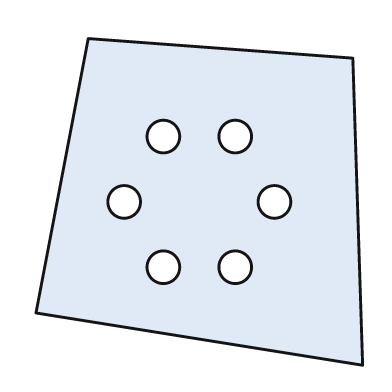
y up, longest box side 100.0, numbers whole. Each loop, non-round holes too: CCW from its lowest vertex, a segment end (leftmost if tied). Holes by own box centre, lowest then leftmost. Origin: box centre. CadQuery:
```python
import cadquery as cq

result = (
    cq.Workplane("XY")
    .moveTo(50.0, -50.0)
    .lineTo(47.0, 44.0)
    .lineTo(-34.0, 50.0)
    .lineTo(-50.0, -34.0)
    .close()
    .moveTo(-11.0, -20.0)
    .circle(5.0)
    .moveTo(11.0, -20.0)
    .circle(5.0)
    .moveTo(-23.0, 0.0)
    .circle(5.0)
    .moveTo(23.0, 0.0)
    .circle(5.0)
    .moveTo(-11.0, 20.0)
    .circle(5.0)
    .moveTo(11.0, 20.0)
    .circle(5.0)
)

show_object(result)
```